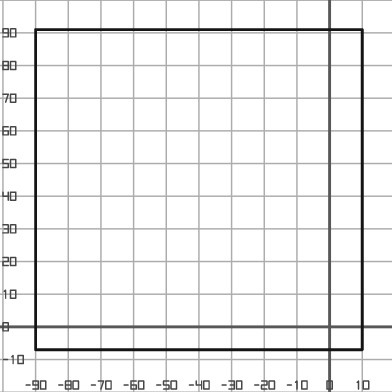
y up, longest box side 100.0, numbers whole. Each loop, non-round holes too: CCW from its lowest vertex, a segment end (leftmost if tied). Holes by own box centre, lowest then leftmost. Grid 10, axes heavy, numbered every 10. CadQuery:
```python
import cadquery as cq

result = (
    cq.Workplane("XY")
    .moveTo(-90.0, -7.0)
    .lineTo(10.0, -7.0)
    .lineTo(10.0, 91.0)
    .lineTo(-90.0, 91.0)
    .close()
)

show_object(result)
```